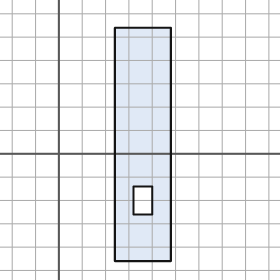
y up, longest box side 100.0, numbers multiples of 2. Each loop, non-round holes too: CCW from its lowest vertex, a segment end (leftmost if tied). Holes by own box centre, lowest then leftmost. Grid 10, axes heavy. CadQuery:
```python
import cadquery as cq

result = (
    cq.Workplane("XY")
    .moveTo(24.0, -46.0)
    .lineTo(48.0, -46.0)
    .lineTo(48.0, 54.0)
    .lineTo(24.0, 54.0)
    .close()
    .moveTo(32.0, -26.0)
    .lineTo(40.0, -26.0)
    .lineTo(40.0, -14.0)
    .lineTo(32.0, -14.0)
    .close()
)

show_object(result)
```